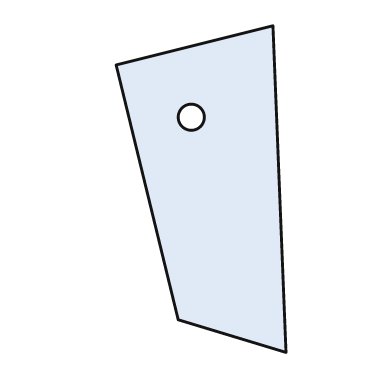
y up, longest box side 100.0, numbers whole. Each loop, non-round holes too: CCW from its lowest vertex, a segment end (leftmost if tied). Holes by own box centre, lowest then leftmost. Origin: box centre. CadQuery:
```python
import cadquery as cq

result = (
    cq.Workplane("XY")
    .moveTo(26.0, -50.0)
    .lineTo(22.0, 50.0)
    .lineTo(-26.0, 38.0)
    .lineTo(-7.0, -40.0)
    .close()
    .moveTo(-3.0, 22.0)
    .circle(4.0)
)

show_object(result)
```